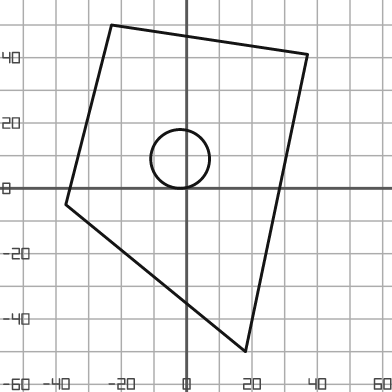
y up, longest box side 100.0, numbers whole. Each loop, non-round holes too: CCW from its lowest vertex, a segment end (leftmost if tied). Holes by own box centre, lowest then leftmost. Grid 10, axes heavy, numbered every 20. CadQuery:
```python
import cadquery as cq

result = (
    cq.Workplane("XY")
    .moveTo(18.0, -50.0)
    .lineTo(37.0, 41.0)
    .lineTo(-23.0, 50.0)
    .lineTo(-37.0, -5.0)
    .close()
    .moveTo(-2.0, 9.0)
    .circle(9.0)
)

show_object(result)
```